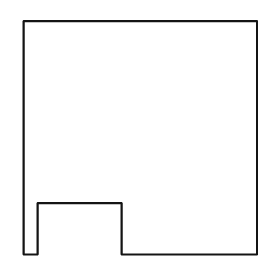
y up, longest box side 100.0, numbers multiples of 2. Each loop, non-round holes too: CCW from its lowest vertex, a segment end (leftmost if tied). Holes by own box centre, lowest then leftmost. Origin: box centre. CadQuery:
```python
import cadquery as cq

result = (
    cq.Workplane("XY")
    .moveTo(-50.0, -50.0)
    .lineTo(-44.0, -50.0)
    .lineTo(-44.0, -28.0)
    .lineTo(-8.0, -28.0)
    .lineTo(-8.0, -50.0)
    .lineTo(50.0, -50.0)
    .lineTo(50.0, 50.0)
    .lineTo(-50.0, 50.0)
    .close()
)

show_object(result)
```